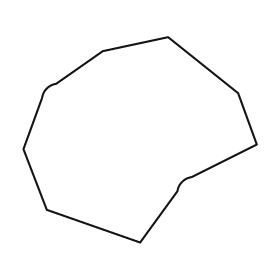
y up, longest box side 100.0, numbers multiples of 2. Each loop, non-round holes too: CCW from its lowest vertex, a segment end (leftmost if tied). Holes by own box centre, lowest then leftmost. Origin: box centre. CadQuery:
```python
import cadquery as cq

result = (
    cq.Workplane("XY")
    .moveTo(0.0, -44.0)
    .lineTo(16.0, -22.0)
    .threePointArc((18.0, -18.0), (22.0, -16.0))
    .lineTo(50.0, -2.0)
    .lineTo(42.0, 20.0)
    .lineTo(12.0, 44.0)
    .lineTo(-16.0, 38.0)
    .lineTo(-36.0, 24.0)
    .threePointArc((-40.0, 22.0), (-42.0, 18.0))
    .lineTo(-50.0, -4.0)
    .lineTo(-40.0, -30.0)
    .close()
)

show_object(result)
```